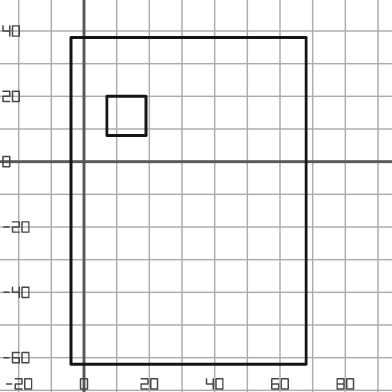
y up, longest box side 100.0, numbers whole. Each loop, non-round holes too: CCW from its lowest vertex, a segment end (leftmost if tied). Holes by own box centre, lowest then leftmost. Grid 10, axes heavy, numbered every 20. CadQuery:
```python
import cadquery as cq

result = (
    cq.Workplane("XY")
    .moveTo(-4.0, -62.0)
    .lineTo(68.0, -62.0)
    .lineTo(68.0, 38.0)
    .lineTo(-4.0, 38.0)
    .close()
    .moveTo(7.0, 8.0)
    .lineTo(19.0, 8.0)
    .lineTo(19.0, 20.0)
    .lineTo(7.0, 20.0)
    .close()
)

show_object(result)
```